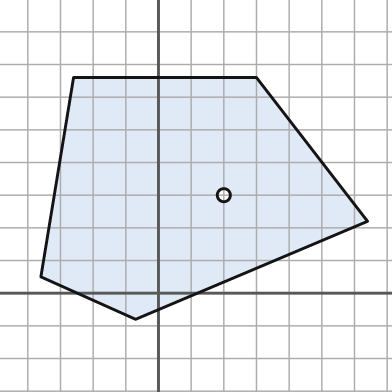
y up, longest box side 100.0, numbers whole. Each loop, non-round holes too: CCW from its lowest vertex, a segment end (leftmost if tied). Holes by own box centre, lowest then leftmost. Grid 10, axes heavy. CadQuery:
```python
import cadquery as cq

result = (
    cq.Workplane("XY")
    .moveTo(-7.0, -8.0)
    .lineTo(64.0, 22.0)
    .lineTo(30.0, 66.0)
    .lineTo(-26.0, 66.0)
    .lineTo(-36.0, 5.0)
    .close()
    .moveTo(20.0, 30.0)
    .circle(2.0)
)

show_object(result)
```